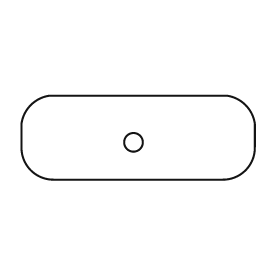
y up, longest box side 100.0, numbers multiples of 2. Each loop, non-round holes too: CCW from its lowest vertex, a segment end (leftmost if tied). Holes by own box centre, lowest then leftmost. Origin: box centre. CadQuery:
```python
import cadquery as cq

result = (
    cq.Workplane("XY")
    .moveTo(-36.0, -18.0)
    .lineTo(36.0, -18.0)
    .threePointArc((46.0, -14.0), (50.0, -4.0))
    .lineTo(50.0, 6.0)
    .threePointArc((46.0, 14.0), (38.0, 18.0))
    .lineTo(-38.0, 18.0)
    .threePointArc((-46.0, 14.0), (-50.0, 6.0))
    .lineTo(-50.0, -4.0)
    .threePointArc((-46.0, -14.0), (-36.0, -18.0))
    .close()
    .moveTo(-2.0, -2.0)
    .circle(4.0)
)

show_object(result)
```